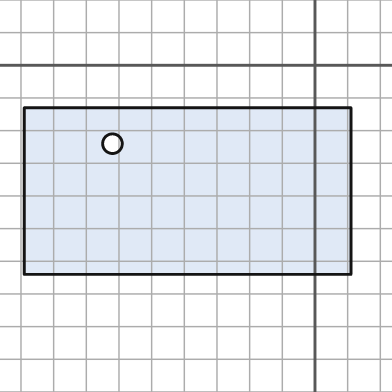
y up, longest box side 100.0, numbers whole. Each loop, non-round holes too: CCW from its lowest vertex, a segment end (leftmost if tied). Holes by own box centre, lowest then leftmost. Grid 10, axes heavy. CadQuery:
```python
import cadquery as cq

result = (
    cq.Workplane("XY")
    .moveTo(-89.0, -64.0)
    .lineTo(11.0, -64.0)
    .lineTo(11.0, -13.0)
    .lineTo(-89.0, -13.0)
    .close()
    .moveTo(-62.0, -24.0)
    .circle(3.0)
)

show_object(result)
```